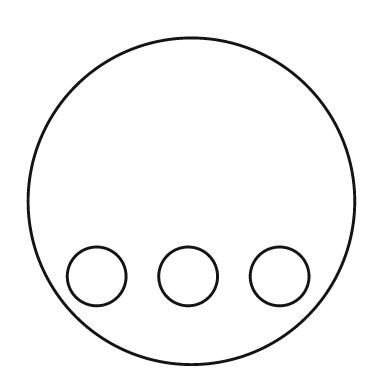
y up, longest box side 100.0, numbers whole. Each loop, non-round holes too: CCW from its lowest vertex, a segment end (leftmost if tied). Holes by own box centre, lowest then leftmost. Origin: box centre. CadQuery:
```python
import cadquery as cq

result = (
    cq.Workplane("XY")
    .moveTo(0.0, 0.0)
    .circle(50.0)
    .moveTo(-29.0, -23.0)
    .circle(9.0)
    .moveTo(-1.0, -23.0)
    .circle(9.0)
    .moveTo(27.0, -23.0)
    .circle(9.0)
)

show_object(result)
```